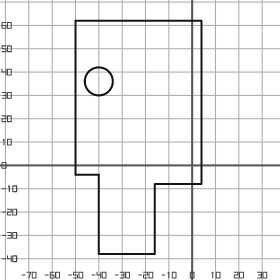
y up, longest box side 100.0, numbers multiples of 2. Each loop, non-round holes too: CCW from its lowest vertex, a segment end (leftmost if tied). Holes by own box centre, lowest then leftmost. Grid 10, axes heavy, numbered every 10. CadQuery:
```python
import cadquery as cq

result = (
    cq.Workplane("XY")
    .moveTo(-40.0, -38.0)
    .lineTo(-16.0, -38.0)
    .lineTo(-16.0, -8.0)
    .lineTo(4.0, -8.0)
    .lineTo(4.0, 62.0)
    .lineTo(-50.0, 62.0)
    .lineTo(-50.0, -4.0)
    .lineTo(-40.0, -4.0)
    .close()
    .moveTo(-40.0, 36.0)
    .circle(6.0)
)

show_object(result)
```